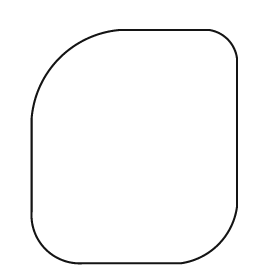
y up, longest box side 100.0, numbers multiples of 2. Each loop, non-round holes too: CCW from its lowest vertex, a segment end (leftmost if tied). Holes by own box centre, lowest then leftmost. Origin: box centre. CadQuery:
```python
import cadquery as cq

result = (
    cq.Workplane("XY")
    .moveTo(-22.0, -50.0)
    .lineTo(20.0, -50.0)
    .threePointArc((36.0, -42.0), (44.0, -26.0))
    .lineTo(44.0, 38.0)
    .threePointArc((40.0, 46.0), (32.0, 50.0))
    .lineTo(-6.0, 50.0)
    .threePointArc((-32.0, 38.0), (-44.0, 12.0))
    .lineTo(-44.0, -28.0)
    .threePointArc((-38.0, -44.0), (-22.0, -50.0))
    .close()
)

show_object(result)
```